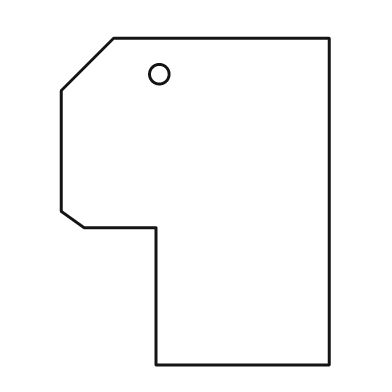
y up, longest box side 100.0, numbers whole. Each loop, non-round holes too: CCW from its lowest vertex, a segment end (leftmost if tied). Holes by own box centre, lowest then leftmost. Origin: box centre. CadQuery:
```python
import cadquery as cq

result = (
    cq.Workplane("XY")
    .moveTo(-12.0, -50.0)
    .lineTo(41.0, -50.0)
    .lineTo(41.0, 50.0)
    .lineTo(-25.0, 50.0)
    .lineTo(-41.0, 34.0)
    .lineTo(-41.0, -3.0)
    .lineTo(-34.0, -8.0)
    .lineTo(-12.0, -8.0)
    .close()
    .moveTo(-11.0, 39.0)
    .circle(3.0)
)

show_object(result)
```